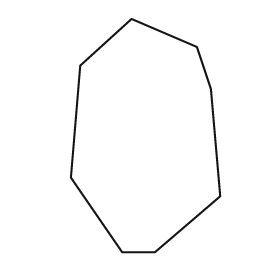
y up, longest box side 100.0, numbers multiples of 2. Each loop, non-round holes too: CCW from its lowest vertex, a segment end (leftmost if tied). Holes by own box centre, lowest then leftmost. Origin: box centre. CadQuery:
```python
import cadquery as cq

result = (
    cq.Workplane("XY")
    .moveTo(-10.0, -50.0)
    .lineTo(4.0, -50.0)
    .lineTo(32.0, -26.0)
    .lineTo(28.0, 20.0)
    .lineTo(22.0, 38.0)
    .lineTo(-6.0, 50.0)
    .lineTo(-28.0, 30.0)
    .lineTo(-32.0, -18.0)
    .close()
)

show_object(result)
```